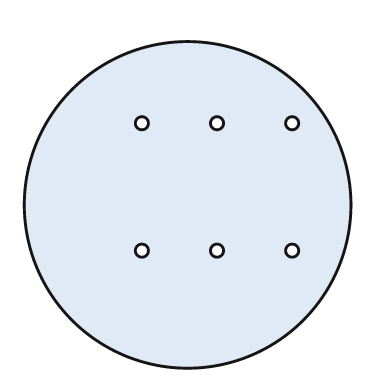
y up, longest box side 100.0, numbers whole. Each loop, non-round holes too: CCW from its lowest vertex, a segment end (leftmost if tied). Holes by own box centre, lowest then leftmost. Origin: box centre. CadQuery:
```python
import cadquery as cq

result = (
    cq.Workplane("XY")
    .moveTo(0.0, 0.0)
    .circle(50.0)
    .moveTo(-14.0, -14.0)
    .circle(2.0)
    .moveTo(9.0, -14.0)
    .circle(2.0)
    .moveTo(32.0, -14.0)
    .circle(2.0)
    .moveTo(-14.0, 25.0)
    .circle(2.0)
    .moveTo(9.0, 25.0)
    .circle(2.0)
    .moveTo(32.0, 25.0)
    .circle(2.0)
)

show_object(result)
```